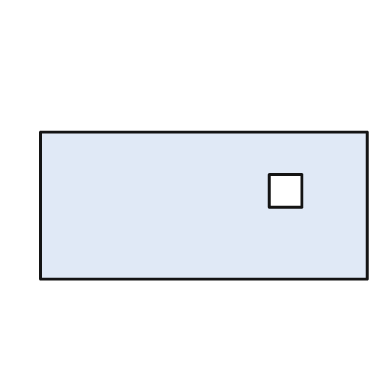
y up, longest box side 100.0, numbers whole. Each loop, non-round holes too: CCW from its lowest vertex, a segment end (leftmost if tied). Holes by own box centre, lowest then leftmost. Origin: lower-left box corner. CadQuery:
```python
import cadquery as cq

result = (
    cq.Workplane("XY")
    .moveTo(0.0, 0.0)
    .lineTo(100.0, 0.0)
    .lineTo(100.0, 45.0)
    .lineTo(0.0, 45.0)
    .close()
    .moveTo(70.0, 22.0)
    .lineTo(80.0, 22.0)
    .lineTo(80.0, 32.0)
    .lineTo(70.0, 32.0)
    .close()
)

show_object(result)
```